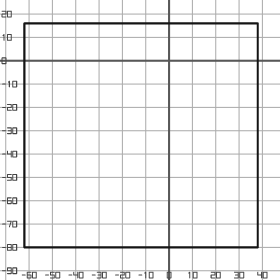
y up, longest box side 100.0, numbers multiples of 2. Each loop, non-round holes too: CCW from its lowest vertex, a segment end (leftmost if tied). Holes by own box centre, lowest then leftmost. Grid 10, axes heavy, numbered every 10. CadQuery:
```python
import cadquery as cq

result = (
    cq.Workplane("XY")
    .moveTo(-62.0, -80.0)
    .lineTo(38.0, -80.0)
    .lineTo(38.0, 16.0)
    .lineTo(-62.0, 16.0)
    .close()
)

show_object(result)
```